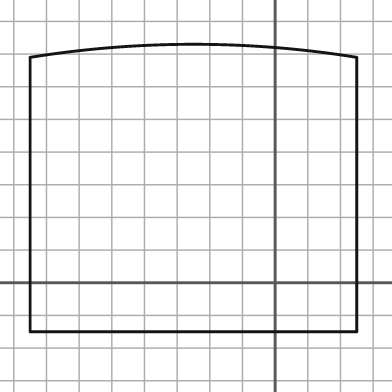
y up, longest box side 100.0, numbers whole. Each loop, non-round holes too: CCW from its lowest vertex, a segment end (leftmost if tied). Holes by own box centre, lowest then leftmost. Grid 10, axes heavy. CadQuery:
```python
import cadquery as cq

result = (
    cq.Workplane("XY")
    .moveTo(-75.0, -15.0)
    .lineTo(25.0, -15.0)
    .lineTo(25.0, 69.0)
    .threePointArc((-25.0, 73.0), (-75.0, 69.0))
    .close()
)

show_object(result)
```